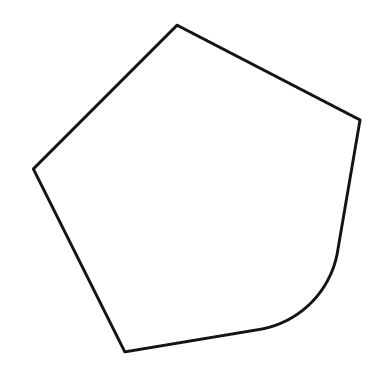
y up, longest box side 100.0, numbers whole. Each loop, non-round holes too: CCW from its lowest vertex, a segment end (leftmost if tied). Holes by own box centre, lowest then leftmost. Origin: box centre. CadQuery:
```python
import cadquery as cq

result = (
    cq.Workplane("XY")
    .moveTo(-22.0, -50.0)
    .lineTo(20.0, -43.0)
    .threePointArc((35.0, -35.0), (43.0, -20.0))
    .lineTo(50.0, 21.0)
    .lineTo(-6.0, 50.0)
    .lineTo(-50.0, 6.0)
    .close()
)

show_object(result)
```